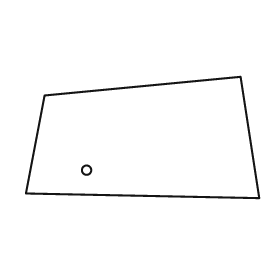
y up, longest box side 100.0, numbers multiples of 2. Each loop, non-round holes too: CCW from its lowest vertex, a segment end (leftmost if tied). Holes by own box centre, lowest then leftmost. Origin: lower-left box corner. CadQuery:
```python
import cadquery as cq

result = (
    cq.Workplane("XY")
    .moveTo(100.0, 0.0)
    .lineTo(92.0, 52.0)
    .lineTo(8.0, 44.0)
    .lineTo(0.0, 2.0)
    .close()
    .moveTo(26.0, 12.0)
    .circle(2.0)
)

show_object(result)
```